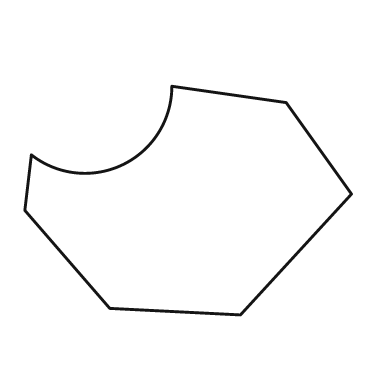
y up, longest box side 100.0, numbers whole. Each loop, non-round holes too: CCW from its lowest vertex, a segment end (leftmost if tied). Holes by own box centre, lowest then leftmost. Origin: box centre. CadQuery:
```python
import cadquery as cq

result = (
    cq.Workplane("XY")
    .moveTo(16.0, -35.0)
    .lineTo(50.0, 2.0)
    .lineTo(30.0, 30.0)
    .lineTo(-5.0, 35.0)
    .threePointArc((-20.0, 11.0), (-48.0, 14.0))
    .lineTo(-50.0, -3.0)
    .lineTo(-24.0, -33.0)
    .close()
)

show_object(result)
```